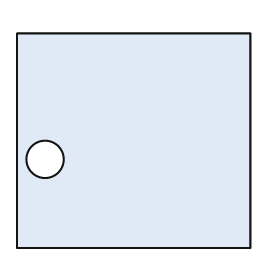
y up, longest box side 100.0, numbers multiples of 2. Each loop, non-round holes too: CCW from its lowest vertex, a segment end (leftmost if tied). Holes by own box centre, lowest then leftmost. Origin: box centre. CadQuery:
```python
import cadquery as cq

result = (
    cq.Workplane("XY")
    .moveTo(-50.0, -46.0)
    .lineTo(50.0, -46.0)
    .lineTo(50.0, 46.0)
    .lineTo(-50.0, 46.0)
    .close()
    .moveTo(-38.0, -8.0)
    .circle(8.0)
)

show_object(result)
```